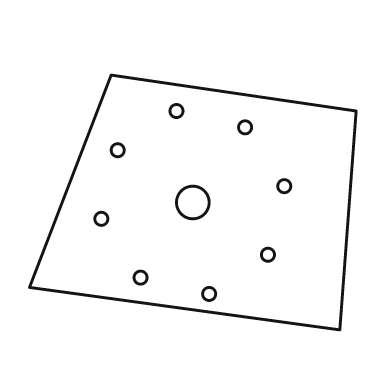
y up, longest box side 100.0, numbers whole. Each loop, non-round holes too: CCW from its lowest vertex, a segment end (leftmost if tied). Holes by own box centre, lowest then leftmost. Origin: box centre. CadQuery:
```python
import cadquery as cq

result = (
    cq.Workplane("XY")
    .moveTo(45.0, -39.0)
    .lineTo(50.0, 28.0)
    .lineTo(-25.0, 39.0)
    .lineTo(-50.0, -26.0)
    .close()
    .moveTo(5.0, -28.0)
    .circle(2.0)
    .moveTo(-16.0, -23.0)
    .circle(2.0)
    .moveTo(23.0, -16.0)
    .circle(2.0)
    .moveTo(-28.0, -5.0)
    .circle(2.0)
    .moveTo(0.0, 0.0)
    .circle(5.0)
    .moveTo(28.0, 5.0)
    .circle(2.0)
    .moveTo(-23.0, 16.0)
    .circle(2.0)
    .moveTo(16.0, 23.0)
    .circle(2.0)
    .moveTo(-5.0, 28.0)
    .circle(2.0)
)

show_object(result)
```